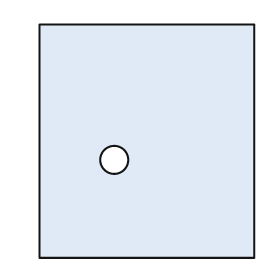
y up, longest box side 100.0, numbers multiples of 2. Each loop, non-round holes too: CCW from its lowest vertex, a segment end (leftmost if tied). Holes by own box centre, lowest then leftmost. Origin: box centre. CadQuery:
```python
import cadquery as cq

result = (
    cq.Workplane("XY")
    .moveTo(-46.0, -50.0)
    .lineTo(46.0, -50.0)
    .lineTo(46.0, 50.0)
    .lineTo(-46.0, 50.0)
    .close()
    .moveTo(-14.0, -8.0)
    .circle(6.0)
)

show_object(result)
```